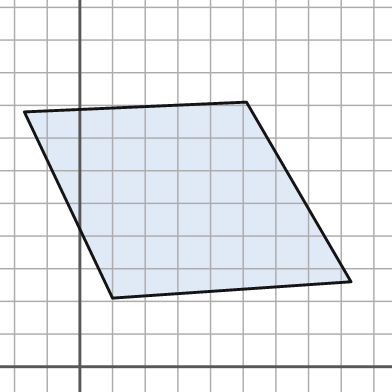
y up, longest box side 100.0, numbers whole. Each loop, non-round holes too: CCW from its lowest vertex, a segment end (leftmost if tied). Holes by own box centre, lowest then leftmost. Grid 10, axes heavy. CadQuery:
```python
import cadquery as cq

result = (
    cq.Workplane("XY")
    .moveTo(10.0, 21.0)
    .lineTo(83.0, 26.0)
    .lineTo(51.0, 81.0)
    .lineTo(-17.0, 78.0)
    .close()
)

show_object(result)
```